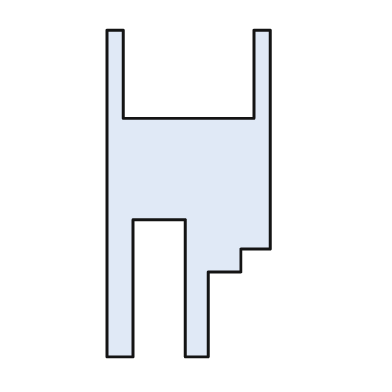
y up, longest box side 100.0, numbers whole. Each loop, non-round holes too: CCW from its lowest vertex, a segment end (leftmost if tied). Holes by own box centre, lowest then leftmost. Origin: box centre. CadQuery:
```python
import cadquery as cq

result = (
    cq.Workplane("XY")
    .moveTo(-25.0, -50.0)
    .lineTo(-17.0, -50.0)
    .lineTo(-17.0, -8.0)
    .lineTo(-1.0, -8.0)
    .lineTo(-1.0, -50.0)
    .lineTo(6.0, -50.0)
    .lineTo(6.0, -24.0)
    .lineTo(16.0, -24.0)
    .lineTo(16.0, -17.0)
    .lineTo(25.0, -17.0)
    .lineTo(25.0, 50.0)
    .lineTo(20.0, 50.0)
    .lineTo(20.0, 23.0)
    .lineTo(-20.0, 23.0)
    .lineTo(-20.0, 50.0)
    .lineTo(-25.0, 50.0)
    .close()
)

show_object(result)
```